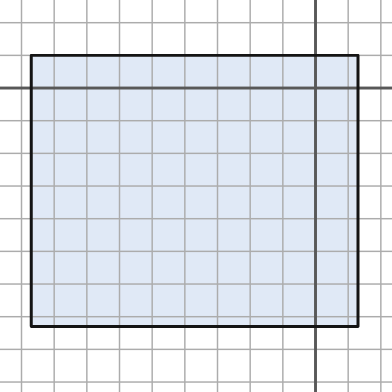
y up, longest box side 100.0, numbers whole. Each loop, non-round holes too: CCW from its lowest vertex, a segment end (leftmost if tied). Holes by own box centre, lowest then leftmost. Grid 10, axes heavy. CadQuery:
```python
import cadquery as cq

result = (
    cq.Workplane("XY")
    .moveTo(-87.0, -73.0)
    .lineTo(13.0, -73.0)
    .lineTo(13.0, 10.0)
    .lineTo(-87.0, 10.0)
    .close()
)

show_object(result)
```